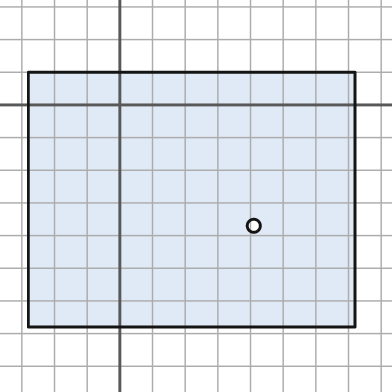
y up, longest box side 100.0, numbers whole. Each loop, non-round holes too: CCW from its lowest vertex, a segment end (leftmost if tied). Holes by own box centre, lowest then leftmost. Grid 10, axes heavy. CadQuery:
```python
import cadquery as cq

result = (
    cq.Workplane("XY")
    .moveTo(-28.0, -68.0)
    .lineTo(72.0, -68.0)
    .lineTo(72.0, 10.0)
    .lineTo(-28.0, 10.0)
    .close()
    .moveTo(41.0, -37.0)
    .circle(2.0)
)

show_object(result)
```